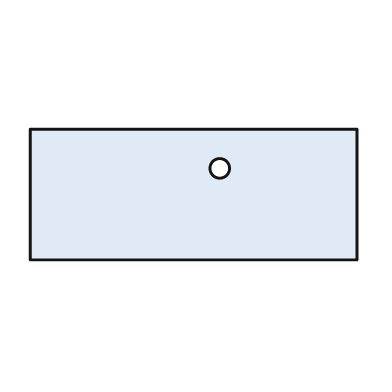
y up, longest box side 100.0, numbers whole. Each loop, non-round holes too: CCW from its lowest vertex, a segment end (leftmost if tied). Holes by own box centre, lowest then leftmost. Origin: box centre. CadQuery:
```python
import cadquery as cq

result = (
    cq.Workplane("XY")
    .moveTo(-50.0, -20.0)
    .lineTo(50.0, -20.0)
    .lineTo(50.0, 20.0)
    .lineTo(-50.0, 20.0)
    .close()
    .moveTo(8.0, 8.0)
    .circle(3.0)
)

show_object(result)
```